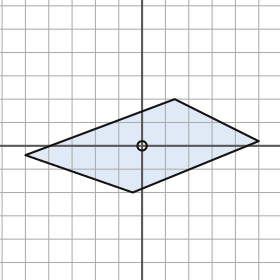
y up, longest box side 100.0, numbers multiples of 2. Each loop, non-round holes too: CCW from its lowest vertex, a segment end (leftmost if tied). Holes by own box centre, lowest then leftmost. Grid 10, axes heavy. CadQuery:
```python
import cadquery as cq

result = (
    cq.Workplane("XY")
    .moveTo(-4.0, -20.0)
    .lineTo(50.0, 2.0)
    .lineTo(14.0, 20.0)
    .lineTo(-50.0, -4.0)
    .close()
    .moveTo(0.0, 0.0)
    .circle(2.0)
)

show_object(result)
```